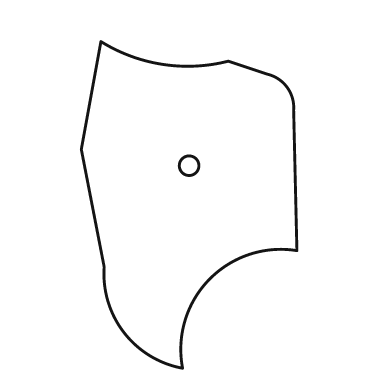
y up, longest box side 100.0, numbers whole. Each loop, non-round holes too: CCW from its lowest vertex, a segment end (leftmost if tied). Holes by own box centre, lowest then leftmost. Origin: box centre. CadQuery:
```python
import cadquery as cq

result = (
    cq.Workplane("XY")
    .moveTo(-2.0, -50.0)
    .threePointArc((6.0, -23.0), (33.0, -14.0))
    .lineTo(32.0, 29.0)
    .threePointArc((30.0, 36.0), (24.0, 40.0))
    .lineTo(12.0, 44.0)
    .threePointArc((-8.0, 43.0), (-27.0, 50.0))
    .lineTo(-33.0, 17.0)
    .lineTo(-26.0, -19.0)
    .threePointArc((-20.0, -39.0), (-2.0, -50.0))
    .close()
    .moveTo(0.0, 12.0)
    .circle(3.0)
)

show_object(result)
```